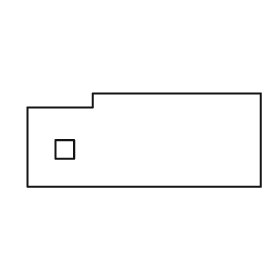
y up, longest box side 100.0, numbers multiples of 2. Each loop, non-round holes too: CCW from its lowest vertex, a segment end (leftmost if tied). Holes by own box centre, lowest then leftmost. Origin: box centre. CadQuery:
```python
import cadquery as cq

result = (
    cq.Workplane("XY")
    .moveTo(-50.0, -20.0)
    .lineTo(50.0, -20.0)
    .lineTo(50.0, 20.0)
    .lineTo(-22.0, 20.0)
    .lineTo(-22.0, 14.0)
    .lineTo(-50.0, 14.0)
    .close()
    .moveTo(-38.0, -8.0)
    .lineTo(-30.0, -8.0)
    .lineTo(-30.0, 0.0)
    .lineTo(-38.0, 0.0)
    .close()
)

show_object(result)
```